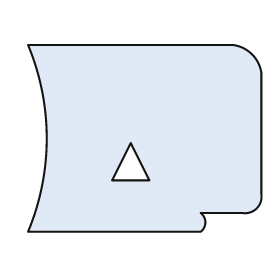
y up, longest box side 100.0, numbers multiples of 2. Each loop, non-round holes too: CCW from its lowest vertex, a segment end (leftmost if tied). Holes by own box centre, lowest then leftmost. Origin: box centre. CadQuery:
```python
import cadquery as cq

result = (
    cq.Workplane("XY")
    .moveTo(-50.0, -40.0)
    .lineTo(24.0, -40.0)
    .threePointArc((26.0, -36.0), (24.0, -32.0))
    .lineTo(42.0, -32.0)
    .threePointArc((48.0, -30.0), (50.0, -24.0))
    .lineTo(50.0, 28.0)
    .threePointArc((46.0, 36.0), (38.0, 40.0))
    .lineTo(-50.0, 40.0)
    .threePointArc((-42.0, 0.0), (-50.0, -40.0))
    .close()
    .moveTo(-14.0, -18.0)
    .lineTo(2.0, -18.0)
    .lineTo(-6.0, -2.0)
    .close()
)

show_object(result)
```